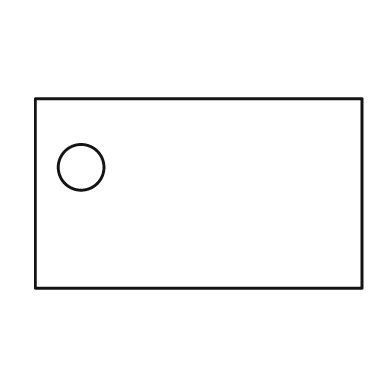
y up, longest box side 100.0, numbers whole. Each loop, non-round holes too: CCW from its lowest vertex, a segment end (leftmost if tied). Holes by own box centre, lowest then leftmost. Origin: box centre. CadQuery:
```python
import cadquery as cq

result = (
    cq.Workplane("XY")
    .moveTo(-50.0, -29.0)
    .lineTo(50.0, -29.0)
    .lineTo(50.0, 29.0)
    .lineTo(-50.0, 29.0)
    .close()
    .moveTo(-36.0, 8.0)
    .circle(7.0)
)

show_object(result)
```